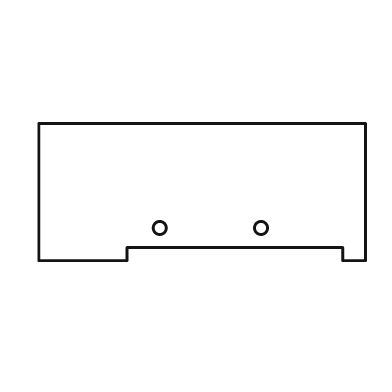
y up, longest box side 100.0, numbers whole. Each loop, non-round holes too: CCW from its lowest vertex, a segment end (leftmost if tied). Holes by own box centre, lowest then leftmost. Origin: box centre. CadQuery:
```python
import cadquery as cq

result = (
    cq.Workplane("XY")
    .moveTo(-50.0, -21.0)
    .lineTo(-23.0, -21.0)
    .lineTo(-23.0, -17.0)
    .lineTo(43.0, -17.0)
    .lineTo(43.0, -21.0)
    .lineTo(50.0, -21.0)
    .lineTo(50.0, 21.0)
    .lineTo(-50.0, 21.0)
    .close()
    .moveTo(-13.0, -11.0)
    .circle(2.0)
    .moveTo(18.0, -11.0)
    .circle(2.0)
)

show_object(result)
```